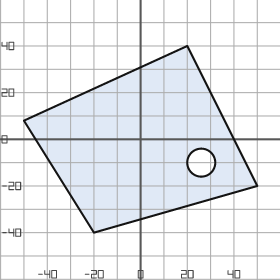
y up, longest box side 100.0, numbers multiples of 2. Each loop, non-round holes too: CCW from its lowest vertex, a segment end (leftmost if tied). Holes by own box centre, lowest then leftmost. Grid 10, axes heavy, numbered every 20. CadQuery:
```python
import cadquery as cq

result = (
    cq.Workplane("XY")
    .moveTo(-20.0, -40.0)
    .lineTo(50.0, -20.0)
    .lineTo(20.0, 40.0)
    .lineTo(-50.0, 8.0)
    .close()
    .moveTo(26.0, -10.0)
    .circle(6.0)
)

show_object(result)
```